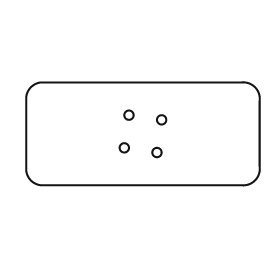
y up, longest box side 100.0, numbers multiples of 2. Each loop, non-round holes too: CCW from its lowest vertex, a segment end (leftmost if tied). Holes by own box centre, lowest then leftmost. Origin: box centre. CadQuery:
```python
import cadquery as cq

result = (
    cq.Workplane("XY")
    .moveTo(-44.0, -22.0)
    .lineTo(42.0, -22.0)
    .threePointArc((48.0, -20.0), (50.0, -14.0))
    .lineTo(50.0, 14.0)
    .threePointArc((48.0, 20.0), (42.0, 22.0))
    .lineTo(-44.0, 22.0)
    .threePointArc((-48.0, 20.0), (-50.0, 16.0))
    .lineTo(-50.0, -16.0)
    .threePointArc((-48.0, -20.0), (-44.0, -22.0))
    .close()
    .moveTo(6.0, -8.0)
    .circle(2.0)
    .moveTo(-8.0, -6.0)
    .circle(2.0)
    .moveTo(8.0, 6.0)
    .circle(2.0)
    .moveTo(-6.0, 8.0)
    .circle(2.0)
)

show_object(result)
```